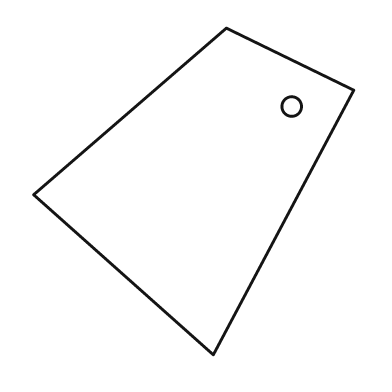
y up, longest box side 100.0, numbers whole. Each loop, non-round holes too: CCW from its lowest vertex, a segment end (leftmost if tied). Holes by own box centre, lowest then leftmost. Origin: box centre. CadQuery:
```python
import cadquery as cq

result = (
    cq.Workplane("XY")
    .moveTo(6.0, -50.0)
    .lineTo(49.0, 31.0)
    .lineTo(10.0, 50.0)
    .lineTo(-49.0, -1.0)
    .close()
    .moveTo(30.0, 26.0)
    .circle(3.0)
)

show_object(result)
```